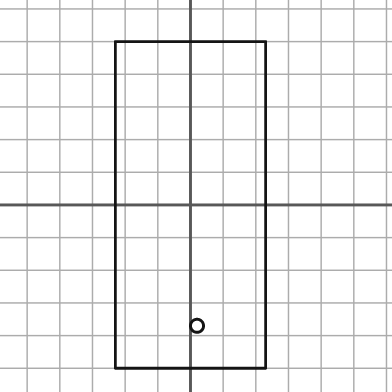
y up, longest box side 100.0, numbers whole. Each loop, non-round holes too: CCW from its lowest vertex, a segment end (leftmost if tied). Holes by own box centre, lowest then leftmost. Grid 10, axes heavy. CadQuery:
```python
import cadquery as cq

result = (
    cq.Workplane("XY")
    .moveTo(-23.0, -50.0)
    .lineTo(23.0, -50.0)
    .lineTo(23.0, 50.0)
    .lineTo(-23.0, 50.0)
    .close()
    .moveTo(2.0, -37.0)
    .circle(2.0)
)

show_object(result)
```